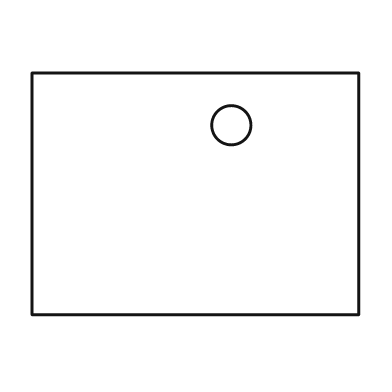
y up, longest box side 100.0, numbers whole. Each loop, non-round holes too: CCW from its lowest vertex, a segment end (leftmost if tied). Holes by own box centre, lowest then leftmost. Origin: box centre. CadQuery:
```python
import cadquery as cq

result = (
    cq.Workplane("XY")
    .moveTo(-50.0, -37.0)
    .lineTo(50.0, -37.0)
    .lineTo(50.0, 37.0)
    .lineTo(-50.0, 37.0)
    .close()
    .moveTo(11.0, 21.0)
    .circle(6.0)
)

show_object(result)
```